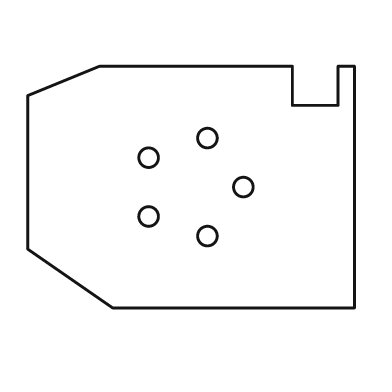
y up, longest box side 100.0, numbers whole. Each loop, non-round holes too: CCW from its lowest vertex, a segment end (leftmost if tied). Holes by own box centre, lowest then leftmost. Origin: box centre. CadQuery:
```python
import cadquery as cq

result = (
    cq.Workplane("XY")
    .moveTo(-24.0, -37.0)
    .lineTo(50.0, -37.0)
    .lineTo(50.0, 37.0)
    .lineTo(45.0, 37.0)
    .lineTo(45.0, 25.0)
    .lineTo(31.0, 25.0)
    .lineTo(31.0, 37.0)
    .lineTo(-28.0, 37.0)
    .lineTo(-50.0, 28.0)
    .lineTo(-50.0, -19.0)
    .close()
    .moveTo(5.0, -15.0)
    .circle(3.0)
    .moveTo(-13.0, -9.0)
    .circle(3.0)
    .moveTo(16.0, 0.0)
    .circle(3.0)
    .moveTo(-13.0, 9.0)
    .circle(3.0)
    .moveTo(5.0, 15.0)
    .circle(3.0)
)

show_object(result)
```